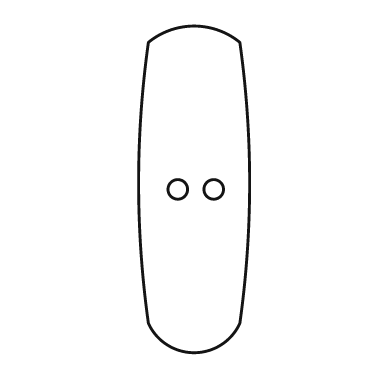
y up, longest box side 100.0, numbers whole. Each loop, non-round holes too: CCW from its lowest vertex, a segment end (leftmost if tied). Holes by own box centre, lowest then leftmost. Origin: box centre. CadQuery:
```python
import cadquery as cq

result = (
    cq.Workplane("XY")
    .moveTo(-14.0, -41.0)
    .threePointArc((0.0, -50.0), (14.0, -41.0))
    .threePointArc((17.0, 2.0), (14.0, 45.0))
    .threePointArc((0.0, 50.0), (-14.0, 45.0))
    .threePointArc((-17.0, 2.0), (-14.0, -41.0))
    .close()
    .moveTo(-5.0, 0.0)
    .circle(3.0)
    .moveTo(6.0, 0.0)
    .circle(3.0)
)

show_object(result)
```